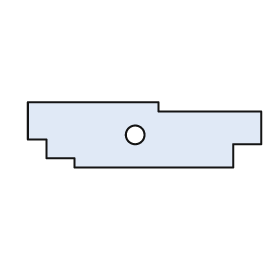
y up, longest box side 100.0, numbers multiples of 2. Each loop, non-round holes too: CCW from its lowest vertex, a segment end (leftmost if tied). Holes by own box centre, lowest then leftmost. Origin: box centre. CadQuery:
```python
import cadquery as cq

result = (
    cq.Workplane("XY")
    .moveTo(-30.0, -14.0)
    .lineTo(38.0, -14.0)
    .lineTo(38.0, -4.0)
    .lineTo(50.0, -4.0)
    .lineTo(50.0, 10.0)
    .lineTo(6.0, 10.0)
    .lineTo(6.0, 14.0)
    .lineTo(-50.0, 14.0)
    .lineTo(-50.0, -2.0)
    .lineTo(-42.0, -2.0)
    .lineTo(-42.0, -10.0)
    .lineTo(-30.0, -10.0)
    .close()
    .moveTo(-4.0, 0.0)
    .circle(4.0)
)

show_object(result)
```